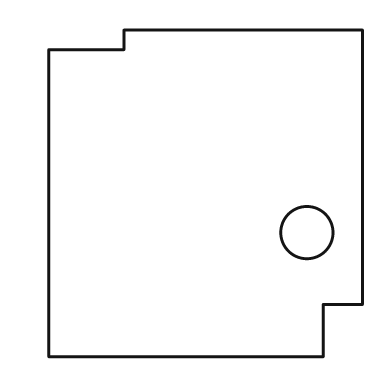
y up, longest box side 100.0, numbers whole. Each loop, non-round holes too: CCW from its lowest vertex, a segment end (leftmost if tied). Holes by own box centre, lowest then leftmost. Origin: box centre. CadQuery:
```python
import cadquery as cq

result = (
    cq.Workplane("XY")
    .moveTo(-48.0, -50.0)
    .lineTo(36.0, -50.0)
    .lineTo(36.0, -34.0)
    .lineTo(48.0, -34.0)
    .lineTo(48.0, 50.0)
    .lineTo(-25.0, 50.0)
    .lineTo(-25.0, 44.0)
    .lineTo(-48.0, 44.0)
    .close()
    .moveTo(31.0, -12.0)
    .circle(8.0)
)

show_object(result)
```